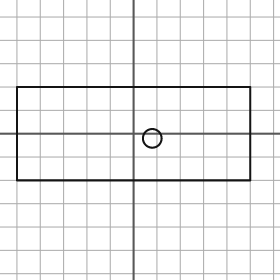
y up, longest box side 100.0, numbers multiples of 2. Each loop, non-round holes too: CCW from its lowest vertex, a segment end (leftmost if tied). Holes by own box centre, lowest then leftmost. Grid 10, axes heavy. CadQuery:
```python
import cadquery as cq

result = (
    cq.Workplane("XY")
    .moveTo(-50.0, -20.0)
    .lineTo(50.0, -20.0)
    .lineTo(50.0, 20.0)
    .lineTo(-50.0, 20.0)
    .close()
    .moveTo(8.0, -2.0)
    .circle(4.0)
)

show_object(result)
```